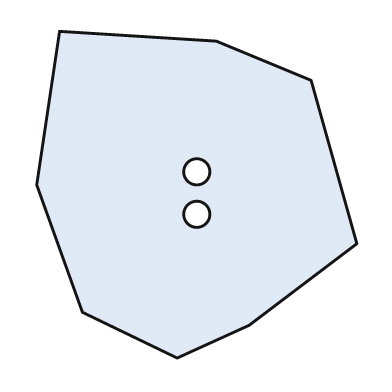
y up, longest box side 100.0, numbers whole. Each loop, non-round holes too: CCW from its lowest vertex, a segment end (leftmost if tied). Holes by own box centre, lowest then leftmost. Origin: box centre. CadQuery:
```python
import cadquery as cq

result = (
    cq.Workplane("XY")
    .moveTo(-6.0, -50.0)
    .lineTo(16.0, -40.0)
    .lineTo(49.0, -15.0)
    .lineTo(35.0, 35.0)
    .lineTo(6.0, 47.0)
    .lineTo(-42.0, 50.0)
    .lineTo(-49.0, 3.0)
    .lineTo(-35.0, -36.0)
    .close()
    .moveTo(0.0, -6.0)
    .circle(4.0)
    .moveTo(0.0, 7.0)
    .circle(4.0)
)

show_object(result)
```